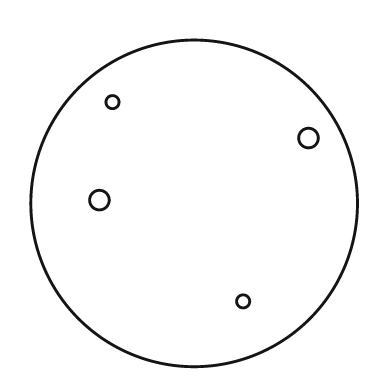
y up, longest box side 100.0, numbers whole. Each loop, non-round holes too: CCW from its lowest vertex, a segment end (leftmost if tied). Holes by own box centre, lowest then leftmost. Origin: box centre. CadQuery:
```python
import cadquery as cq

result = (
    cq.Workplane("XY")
    .moveTo(0.0, 0.0)
    .circle(50.0)
    .moveTo(15.0, -30.0)
    .circle(2.0)
    .moveTo(-29.0, 1.0)
    .circle(3.0)
    .moveTo(35.0, 20.0)
    .circle(3.0)
    .moveTo(-25.0, 31.0)
    .circle(2.0)
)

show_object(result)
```